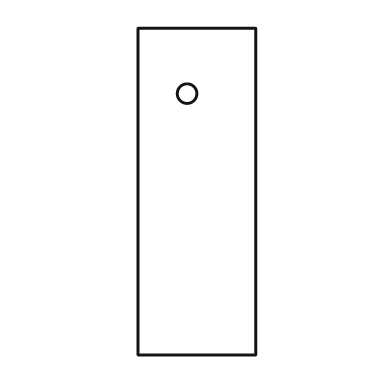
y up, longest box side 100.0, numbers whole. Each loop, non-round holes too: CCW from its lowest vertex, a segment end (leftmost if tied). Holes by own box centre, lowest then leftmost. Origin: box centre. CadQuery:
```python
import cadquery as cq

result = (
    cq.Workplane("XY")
    .moveTo(-18.0, -50.0)
    .lineTo(18.0, -50.0)
    .lineTo(18.0, 50.0)
    .lineTo(-18.0, 50.0)
    .close()
    .moveTo(-3.0, 30.0)
    .circle(3.0)
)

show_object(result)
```